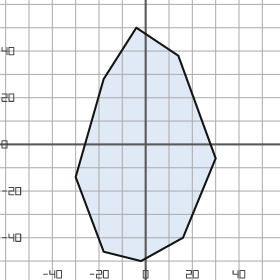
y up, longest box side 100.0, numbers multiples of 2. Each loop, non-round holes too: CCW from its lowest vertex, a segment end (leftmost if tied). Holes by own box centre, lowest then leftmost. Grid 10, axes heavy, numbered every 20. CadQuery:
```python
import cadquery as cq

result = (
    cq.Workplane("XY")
    .moveTo(-2.0, -50.0)
    .lineTo(16.0, -40.0)
    .lineTo(30.0, -6.0)
    .lineTo(14.0, 38.0)
    .lineTo(-4.0, 50.0)
    .lineTo(-18.0, 28.0)
    .lineTo(-30.0, -14.0)
    .lineTo(-18.0, -46.0)
    .close()
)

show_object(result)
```